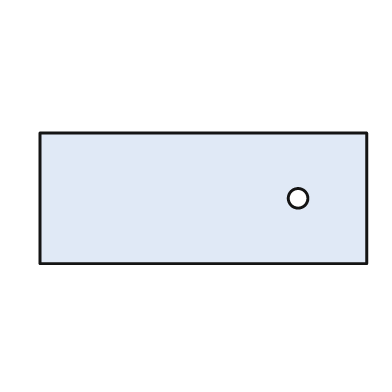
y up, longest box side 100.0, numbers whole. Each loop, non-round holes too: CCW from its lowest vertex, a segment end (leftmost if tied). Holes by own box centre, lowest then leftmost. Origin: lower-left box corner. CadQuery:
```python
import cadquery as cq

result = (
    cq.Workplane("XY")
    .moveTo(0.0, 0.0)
    .lineTo(100.0, 0.0)
    .lineTo(100.0, 40.0)
    .lineTo(0.0, 40.0)
    .close()
    .moveTo(79.0, 20.0)
    .circle(3.0)
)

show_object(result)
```